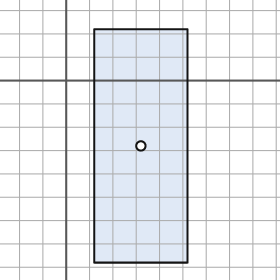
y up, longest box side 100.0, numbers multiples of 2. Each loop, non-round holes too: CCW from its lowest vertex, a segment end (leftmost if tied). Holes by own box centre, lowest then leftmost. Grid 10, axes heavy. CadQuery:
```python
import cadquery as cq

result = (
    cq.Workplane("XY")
    .moveTo(12.0, -78.0)
    .lineTo(52.0, -78.0)
    .lineTo(52.0, 22.0)
    .lineTo(12.0, 22.0)
    .close()
    .moveTo(32.0, -28.0)
    .circle(2.0)
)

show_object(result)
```